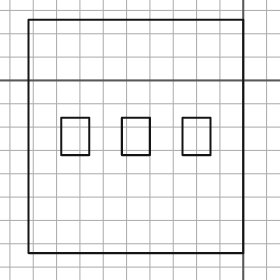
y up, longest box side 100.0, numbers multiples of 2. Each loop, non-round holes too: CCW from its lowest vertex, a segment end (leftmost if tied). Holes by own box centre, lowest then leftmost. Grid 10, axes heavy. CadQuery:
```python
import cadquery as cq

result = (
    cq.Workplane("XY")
    .moveTo(-92.0, -74.0)
    .lineTo(0.0, -74.0)
    .lineTo(0.0, 26.0)
    .lineTo(-92.0, 26.0)
    .close()
    .moveTo(-78.0, -32.0)
    .lineTo(-66.0, -32.0)
    .lineTo(-66.0, -16.0)
    .lineTo(-78.0, -16.0)
    .close()
    .moveTo(-52.0, -32.0)
    .lineTo(-40.0, -32.0)
    .lineTo(-40.0, -16.0)
    .lineTo(-52.0, -16.0)
    .close()
    .moveTo(-26.0, -32.0)
    .lineTo(-14.0, -32.0)
    .lineTo(-14.0, -16.0)
    .lineTo(-26.0, -16.0)
    .close()
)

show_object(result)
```